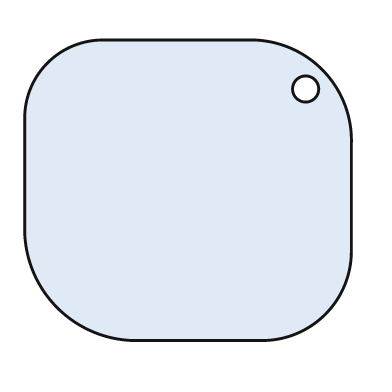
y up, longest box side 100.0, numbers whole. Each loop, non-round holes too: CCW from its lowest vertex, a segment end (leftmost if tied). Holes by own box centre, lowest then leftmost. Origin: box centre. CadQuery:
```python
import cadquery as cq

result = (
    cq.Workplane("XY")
    .moveTo(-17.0, -46.0)
    .lineTo(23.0, -46.0)
    .threePointArc((42.0, -38.0), (50.0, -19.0))
    .lineTo(50.0, 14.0)
    .threePointArc((41.0, 37.0), (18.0, 46.0))
    .lineTo(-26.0, 46.0)
    .threePointArc((-43.0, 39.0), (-50.0, 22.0))
    .lineTo(-50.0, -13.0)
    .threePointArc((-40.0, -36.0), (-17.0, -46.0))
    .close()
    .moveTo(36.0, 31.0)
    .circle(4.0)
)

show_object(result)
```